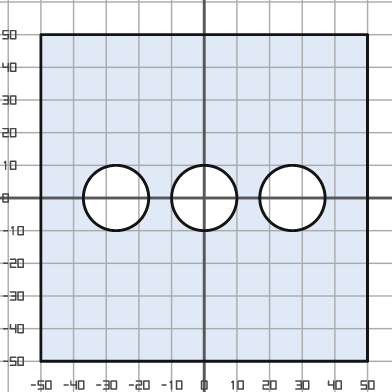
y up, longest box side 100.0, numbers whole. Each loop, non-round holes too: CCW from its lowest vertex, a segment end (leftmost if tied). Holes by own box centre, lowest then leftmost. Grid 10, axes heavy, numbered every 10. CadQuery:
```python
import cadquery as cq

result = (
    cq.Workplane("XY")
    .moveTo(-50.0, -50.0)
    .lineTo(50.0, -50.0)
    .lineTo(50.0, 50.0)
    .lineTo(-50.0, 50.0)
    .close()
    .moveTo(-27.0, 0.0)
    .circle(10.0)
    .moveTo(0.0, 0.0)
    .circle(10.0)
    .moveTo(27.0, 0.0)
    .circle(10.0)
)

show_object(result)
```